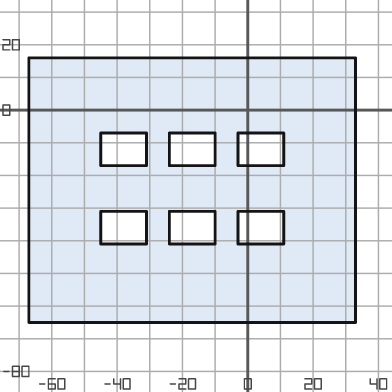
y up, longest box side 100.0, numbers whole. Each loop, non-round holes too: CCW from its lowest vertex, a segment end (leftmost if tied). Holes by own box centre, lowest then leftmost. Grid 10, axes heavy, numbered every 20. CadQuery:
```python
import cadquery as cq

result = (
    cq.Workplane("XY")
    .moveTo(-67.0, -65.0)
    .lineTo(33.0, -65.0)
    .lineTo(33.0, 16.0)
    .lineTo(-67.0, 16.0)
    .close()
    .moveTo(-45.0, -41.0)
    .lineTo(-31.0, -41.0)
    .lineTo(-31.0, -31.0)
    .lineTo(-45.0, -31.0)
    .close()
    .moveTo(-24.0, -41.0)
    .lineTo(-10.0, -41.0)
    .lineTo(-10.0, -31.0)
    .lineTo(-24.0, -31.0)
    .close()
    .moveTo(-3.0, -41.0)
    .lineTo(11.0, -41.0)
    .lineTo(11.0, -31.0)
    .lineTo(-3.0, -31.0)
    .close()
    .moveTo(-45.0, -17.0)
    .lineTo(-31.0, -17.0)
    .lineTo(-31.0, -7.0)
    .lineTo(-45.0, -7.0)
    .close()
    .moveTo(-24.0, -17.0)
    .lineTo(-10.0, -17.0)
    .lineTo(-10.0, -7.0)
    .lineTo(-24.0, -7.0)
    .close()
    .moveTo(-3.0, -17.0)
    .lineTo(11.0, -17.0)
    .lineTo(11.0, -7.0)
    .lineTo(-3.0, -7.0)
    .close()
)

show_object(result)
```